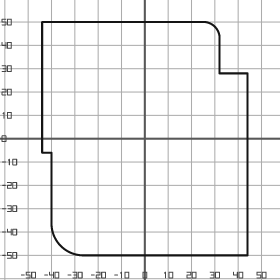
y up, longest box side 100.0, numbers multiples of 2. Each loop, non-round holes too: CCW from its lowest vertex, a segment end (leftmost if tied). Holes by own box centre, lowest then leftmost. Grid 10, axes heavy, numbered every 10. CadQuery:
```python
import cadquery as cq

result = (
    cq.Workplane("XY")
    .moveTo(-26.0, -50.0)
    .lineTo(44.0, -50.0)
    .lineTo(44.0, 28.0)
    .lineTo(32.0, 28.0)
    .lineTo(32.0, 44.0)
    .threePointArc((30.0, 48.0), (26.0, 50.0))
    .lineTo(-44.0, 50.0)
    .lineTo(-44.0, -6.0)
    .lineTo(-40.0, -6.0)
    .lineTo(-40.0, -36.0)
    .threePointArc((-36.0, -46.0), (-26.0, -50.0))
    .close()
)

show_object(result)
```